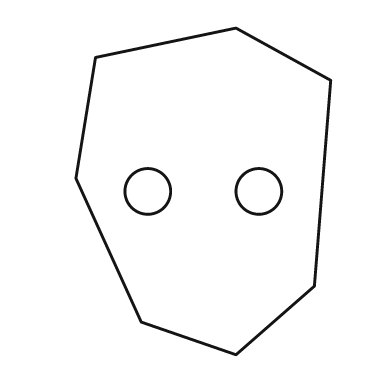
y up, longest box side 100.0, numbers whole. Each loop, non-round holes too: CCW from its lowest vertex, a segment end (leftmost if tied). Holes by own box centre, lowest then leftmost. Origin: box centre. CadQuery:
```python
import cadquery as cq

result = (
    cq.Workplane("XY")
    .moveTo(10.0, -50.0)
    .lineTo(34.0, -29.0)
    .lineTo(39.0, 34.0)
    .lineTo(10.0, 50.0)
    .lineTo(-33.0, 41.0)
    .lineTo(-39.0, 4.0)
    .lineTo(-19.0, -40.0)
    .close()
    .moveTo(-17.0, 0.0)
    .circle(7.0)
    .moveTo(17.0, 0.0)
    .circle(7.0)
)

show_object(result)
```